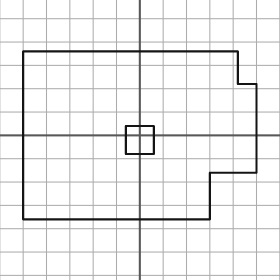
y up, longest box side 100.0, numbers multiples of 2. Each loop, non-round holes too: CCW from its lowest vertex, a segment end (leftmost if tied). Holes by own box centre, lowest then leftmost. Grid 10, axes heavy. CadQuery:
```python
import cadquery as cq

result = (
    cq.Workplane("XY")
    .moveTo(-50.0, -36.0)
    .lineTo(30.0, -36.0)
    .lineTo(30.0, -16.0)
    .lineTo(50.0, -16.0)
    .lineTo(50.0, 22.0)
    .lineTo(42.0, 22.0)
    .lineTo(42.0, 36.0)
    .lineTo(-50.0, 36.0)
    .close()
    .moveTo(-6.0, -8.0)
    .lineTo(6.0, -8.0)
    .lineTo(6.0, 4.0)
    .lineTo(-6.0, 4.0)
    .close()
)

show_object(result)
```